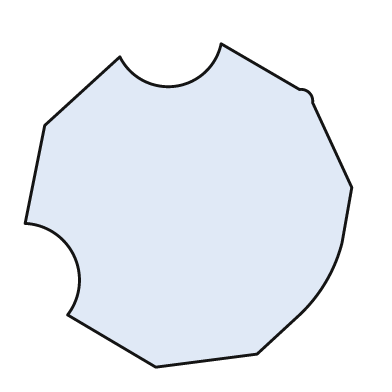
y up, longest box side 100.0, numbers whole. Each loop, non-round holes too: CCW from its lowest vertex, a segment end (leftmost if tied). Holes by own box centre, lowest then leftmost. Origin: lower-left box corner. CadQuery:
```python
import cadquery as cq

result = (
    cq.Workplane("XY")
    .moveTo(40.0, 0.0)
    .lineTo(71.0, 4.0)
    .lineTo(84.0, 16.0)
    .threePointArc((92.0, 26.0), (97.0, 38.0))
    .lineTo(100.0, 55.0)
    .lineTo(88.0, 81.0)
    .threePointArc((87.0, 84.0), (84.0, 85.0))
    .lineTo(60.0, 99.0)
    .threePointArc((46.0, 86.0), (29.0, 95.0))
    .lineTo(6.0, 74.0)
    .lineTo(0.0, 44.0)
    .threePointArc((15.0, 34.0), (13.0, 16.0))
    .close()
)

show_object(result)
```